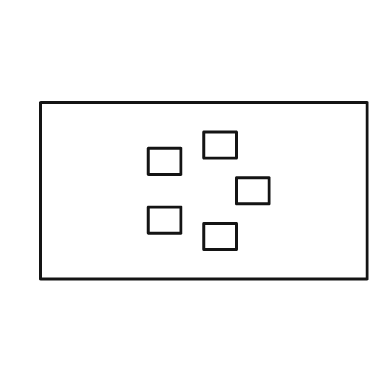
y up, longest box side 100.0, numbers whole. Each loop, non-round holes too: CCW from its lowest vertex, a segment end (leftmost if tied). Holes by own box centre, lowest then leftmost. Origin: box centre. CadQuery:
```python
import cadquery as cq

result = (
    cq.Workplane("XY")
    .moveTo(-50.0, -27.0)
    .lineTo(50.0, -27.0)
    .lineTo(50.0, 27.0)
    .lineTo(-50.0, 27.0)
    .close()
    .moveTo(0.0, -18.0)
    .lineTo(10.0, -18.0)
    .lineTo(10.0, -10.0)
    .lineTo(0.0, -10.0)
    .close()
    .moveTo(-17.0, -13.0)
    .lineTo(-7.0, -13.0)
    .lineTo(-7.0, -5.0)
    .lineTo(-17.0, -5.0)
    .close()
    .moveTo(10.0, -4.0)
    .lineTo(20.0, -4.0)
    .lineTo(20.0, 4.0)
    .lineTo(10.0, 4.0)
    .close()
    .moveTo(-17.0, 5.0)
    .lineTo(-7.0, 5.0)
    .lineTo(-7.0, 13.0)
    .lineTo(-17.0, 13.0)
    .close()
    .moveTo(0.0, 10.0)
    .lineTo(10.0, 10.0)
    .lineTo(10.0, 18.0)
    .lineTo(0.0, 18.0)
    .close()
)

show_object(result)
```